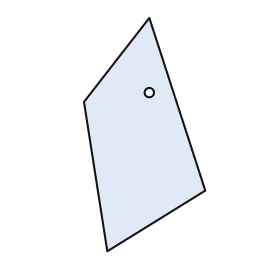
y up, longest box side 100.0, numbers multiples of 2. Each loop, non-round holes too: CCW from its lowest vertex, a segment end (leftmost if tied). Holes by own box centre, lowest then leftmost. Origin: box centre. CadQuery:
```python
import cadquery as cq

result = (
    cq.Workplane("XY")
    .moveTo(-16.0, -50.0)
    .lineTo(26.0, -24.0)
    .lineTo(2.0, 50.0)
    .lineTo(-26.0, 14.0)
    .close()
    .moveTo(2.0, 18.0)
    .circle(2.0)
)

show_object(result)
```